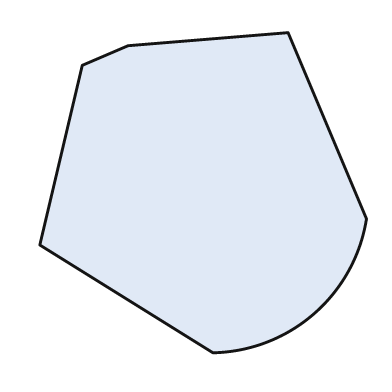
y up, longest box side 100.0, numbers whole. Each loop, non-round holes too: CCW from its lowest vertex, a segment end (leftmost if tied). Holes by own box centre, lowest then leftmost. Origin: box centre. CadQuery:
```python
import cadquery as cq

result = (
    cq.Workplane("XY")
    .moveTo(3.0, -49.0)
    .threePointArc((34.0, -37.0), (50.0, -8.0))
    .lineTo(26.0, 49.0)
    .lineTo(-23.0, 45.0)
    .lineTo(-37.0, 39.0)
    .lineTo(-50.0, -16.0)
    .close()
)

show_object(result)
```